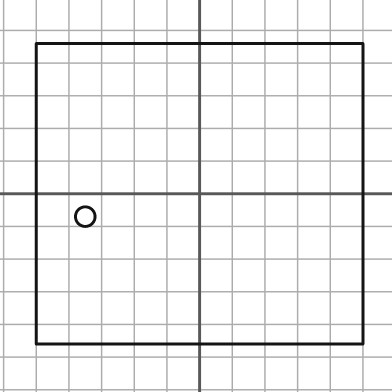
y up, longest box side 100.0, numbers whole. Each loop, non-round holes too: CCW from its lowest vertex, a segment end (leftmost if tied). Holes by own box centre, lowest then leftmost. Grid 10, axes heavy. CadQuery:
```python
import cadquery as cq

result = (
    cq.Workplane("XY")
    .moveTo(-50.0, -46.0)
    .lineTo(50.0, -46.0)
    .lineTo(50.0, 46.0)
    .lineTo(-50.0, 46.0)
    .close()
    .moveTo(-35.0, -7.0)
    .circle(3.0)
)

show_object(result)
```